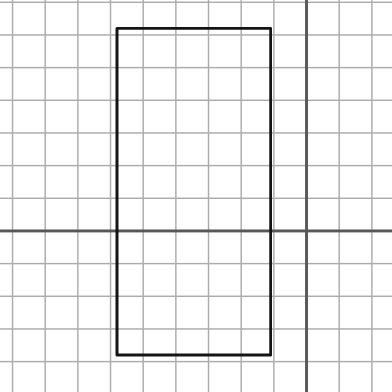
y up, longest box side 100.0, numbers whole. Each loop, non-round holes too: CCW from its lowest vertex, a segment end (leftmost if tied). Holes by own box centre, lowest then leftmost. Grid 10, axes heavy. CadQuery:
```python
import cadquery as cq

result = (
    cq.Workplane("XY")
    .moveTo(-58.0, -38.0)
    .lineTo(-11.0, -38.0)
    .lineTo(-11.0, 62.0)
    .lineTo(-58.0, 62.0)
    .close()
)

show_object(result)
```